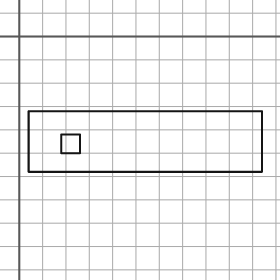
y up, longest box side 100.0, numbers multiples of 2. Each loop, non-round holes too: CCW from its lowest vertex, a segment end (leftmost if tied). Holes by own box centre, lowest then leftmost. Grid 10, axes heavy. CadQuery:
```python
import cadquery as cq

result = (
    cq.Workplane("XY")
    .moveTo(4.0, -58.0)
    .lineTo(104.0, -58.0)
    .lineTo(104.0, -32.0)
    .lineTo(4.0, -32.0)
    .close()
    .moveTo(18.0, -50.0)
    .lineTo(26.0, -50.0)
    .lineTo(26.0, -42.0)
    .lineTo(18.0, -42.0)
    .close()
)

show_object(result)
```